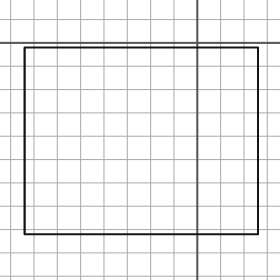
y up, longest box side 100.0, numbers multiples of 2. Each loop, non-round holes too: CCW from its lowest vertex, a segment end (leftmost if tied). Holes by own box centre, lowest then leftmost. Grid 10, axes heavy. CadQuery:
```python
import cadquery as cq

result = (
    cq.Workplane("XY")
    .moveTo(-74.0, -82.0)
    .lineTo(26.0, -82.0)
    .lineTo(26.0, -2.0)
    .lineTo(-74.0, -2.0)
    .close()
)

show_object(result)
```